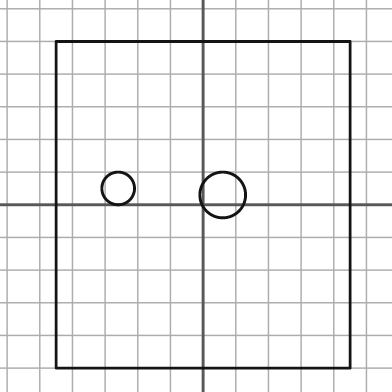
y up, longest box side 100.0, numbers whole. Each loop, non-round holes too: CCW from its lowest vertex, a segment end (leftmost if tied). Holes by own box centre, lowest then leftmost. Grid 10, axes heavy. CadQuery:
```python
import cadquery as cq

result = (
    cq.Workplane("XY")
    .moveTo(-45.0, -50.0)
    .lineTo(45.0, -50.0)
    .lineTo(45.0, 50.0)
    .lineTo(-45.0, 50.0)
    .close()
    .moveTo(6.0, 3.0)
    .circle(7.0)
    .moveTo(-26.0, 5.0)
    .circle(5.0)
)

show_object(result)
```